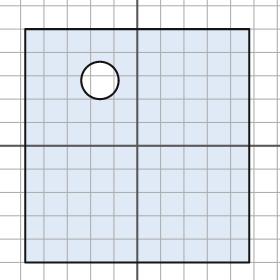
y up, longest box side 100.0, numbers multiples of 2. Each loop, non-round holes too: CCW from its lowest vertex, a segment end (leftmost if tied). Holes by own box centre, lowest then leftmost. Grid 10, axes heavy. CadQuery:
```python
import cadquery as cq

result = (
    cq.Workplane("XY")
    .moveTo(-48.0, -50.0)
    .lineTo(48.0, -50.0)
    .lineTo(48.0, 50.0)
    .lineTo(-48.0, 50.0)
    .close()
    .moveTo(-16.0, 28.0)
    .circle(8.0)
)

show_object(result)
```